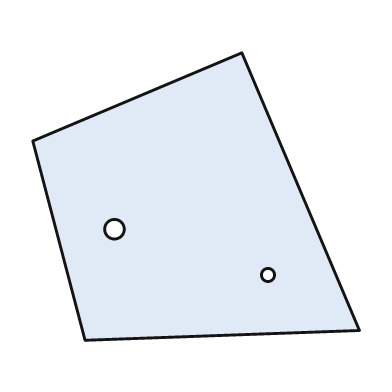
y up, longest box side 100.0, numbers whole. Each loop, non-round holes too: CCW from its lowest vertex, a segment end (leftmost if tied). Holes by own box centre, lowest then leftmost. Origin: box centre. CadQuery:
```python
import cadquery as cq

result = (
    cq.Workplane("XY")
    .moveTo(-34.0, -44.0)
    .lineTo(50.0, -41.0)
    .lineTo(14.0, 44.0)
    .lineTo(-50.0, 17.0)
    .close()
    .moveTo(22.0, -24.0)
    .circle(2.0)
    .moveTo(-25.0, -10.0)
    .circle(3.0)
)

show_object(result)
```